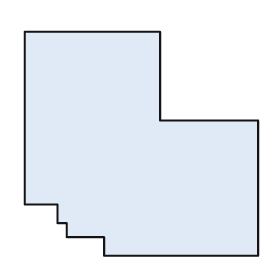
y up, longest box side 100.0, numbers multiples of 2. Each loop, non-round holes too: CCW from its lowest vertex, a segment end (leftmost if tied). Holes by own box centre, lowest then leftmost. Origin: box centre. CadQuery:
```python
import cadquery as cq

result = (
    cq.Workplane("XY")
    .moveTo(-16.0, -48.0)
    .lineTo(50.0, -48.0)
    .lineTo(50.0, 10.0)
    .lineTo(8.0, 10.0)
    .lineTo(8.0, 48.0)
    .lineTo(-50.0, 48.0)
    .lineTo(-50.0, -26.0)
    .lineTo(-36.0, -26.0)
    .lineTo(-36.0, -34.0)
    .lineTo(-32.0, -34.0)
    .lineTo(-32.0, -40.0)
    .lineTo(-16.0, -40.0)
    .close()
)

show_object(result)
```